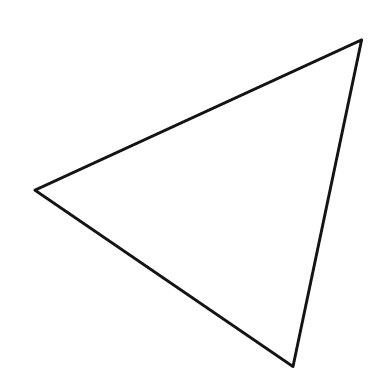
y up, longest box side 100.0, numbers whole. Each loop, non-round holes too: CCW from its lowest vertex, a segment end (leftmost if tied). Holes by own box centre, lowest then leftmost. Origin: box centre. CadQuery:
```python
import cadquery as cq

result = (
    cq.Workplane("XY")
    .moveTo(29.0, -50.0)
    .lineTo(50.0, 50.0)
    .lineTo(-50.0, 4.0)
    .close()
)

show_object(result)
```